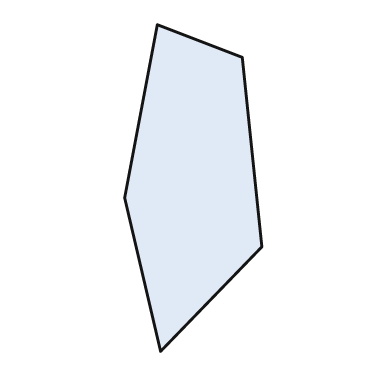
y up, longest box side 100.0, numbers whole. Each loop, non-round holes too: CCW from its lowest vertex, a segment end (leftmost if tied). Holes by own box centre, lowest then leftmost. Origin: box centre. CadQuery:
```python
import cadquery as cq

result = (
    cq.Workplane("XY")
    .moveTo(-10.0, -50.0)
    .lineTo(21.0, -18.0)
    .lineTo(15.0, 40.0)
    .lineTo(-11.0, 50.0)
    .lineTo(-21.0, -3.0)
    .close()
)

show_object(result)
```